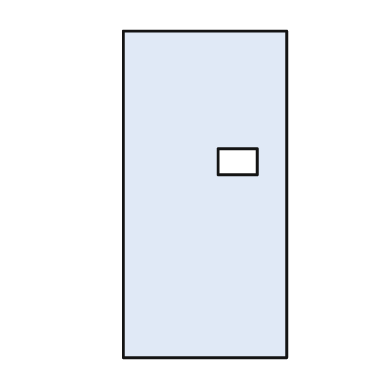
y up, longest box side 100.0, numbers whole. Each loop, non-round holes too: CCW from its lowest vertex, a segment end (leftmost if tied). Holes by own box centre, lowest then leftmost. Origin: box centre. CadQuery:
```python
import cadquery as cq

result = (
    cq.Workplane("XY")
    .moveTo(-25.0, -50.0)
    .lineTo(25.0, -50.0)
    .lineTo(25.0, 50.0)
    .lineTo(-25.0, 50.0)
    .close()
    .moveTo(4.0, 6.0)
    .lineTo(16.0, 6.0)
    .lineTo(16.0, 14.0)
    .lineTo(4.0, 14.0)
    .close()
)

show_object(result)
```